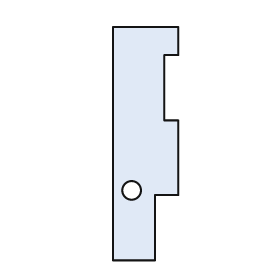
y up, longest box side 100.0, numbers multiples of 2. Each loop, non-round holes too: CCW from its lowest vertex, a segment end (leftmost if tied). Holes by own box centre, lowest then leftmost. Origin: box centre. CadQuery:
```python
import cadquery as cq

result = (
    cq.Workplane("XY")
    .moveTo(-14.0, -50.0)
    .lineTo(4.0, -50.0)
    .lineTo(4.0, -22.0)
    .lineTo(14.0, -22.0)
    .lineTo(14.0, 10.0)
    .lineTo(8.0, 10.0)
    .lineTo(8.0, 38.0)
    .lineTo(14.0, 38.0)
    .lineTo(14.0, 50.0)
    .lineTo(-14.0, 50.0)
    .close()
    .moveTo(-6.0, -20.0)
    .circle(4.0)
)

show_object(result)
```